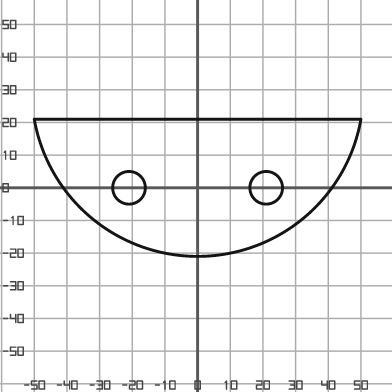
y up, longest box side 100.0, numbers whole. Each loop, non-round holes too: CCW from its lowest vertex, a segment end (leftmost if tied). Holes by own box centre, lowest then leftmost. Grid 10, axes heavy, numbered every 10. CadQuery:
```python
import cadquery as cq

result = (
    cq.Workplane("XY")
    .moveTo(-50.0, 21.0)
    .threePointArc((0.0, -21.0), (50.0, 21.0))
    .close()
    .moveTo(-21.0, 0.0)
    .circle(5.0)
    .moveTo(21.0, 0.0)
    .circle(5.0)
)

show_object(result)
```